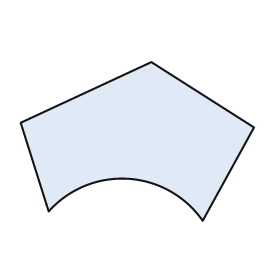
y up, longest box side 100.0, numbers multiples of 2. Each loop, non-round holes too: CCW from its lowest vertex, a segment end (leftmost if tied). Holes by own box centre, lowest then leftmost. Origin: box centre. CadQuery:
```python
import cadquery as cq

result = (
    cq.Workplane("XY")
    .moveTo(28.0, -34.0)
    .lineTo(50.0, 6.0)
    .lineTo(6.0, 34.0)
    .lineTo(-50.0, 8.0)
    .lineTo(-38.0, -30.0)
    .threePointArc((-4.0, -16.0), (28.0, -34.0))
    .close()
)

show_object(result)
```